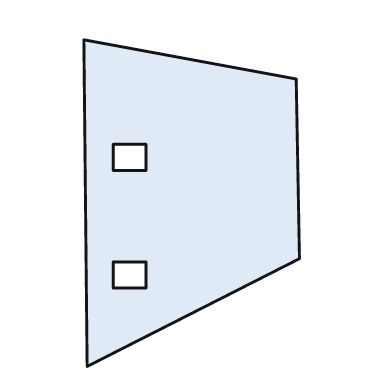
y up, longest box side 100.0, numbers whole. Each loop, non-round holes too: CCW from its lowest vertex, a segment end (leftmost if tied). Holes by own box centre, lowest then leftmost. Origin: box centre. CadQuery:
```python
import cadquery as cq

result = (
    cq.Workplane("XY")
    .moveTo(-32.0, -50.0)
    .lineTo(33.0, -17.0)
    .lineTo(32.0, 38.0)
    .lineTo(-33.0, 50.0)
    .close()
    .moveTo(-24.0, -26.0)
    .lineTo(-14.0, -26.0)
    .lineTo(-14.0, -18.0)
    .lineTo(-24.0, -18.0)
    .close()
    .moveTo(-24.0, 10.0)
    .lineTo(-14.0, 10.0)
    .lineTo(-14.0, 18.0)
    .lineTo(-24.0, 18.0)
    .close()
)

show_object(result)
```